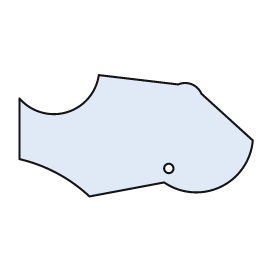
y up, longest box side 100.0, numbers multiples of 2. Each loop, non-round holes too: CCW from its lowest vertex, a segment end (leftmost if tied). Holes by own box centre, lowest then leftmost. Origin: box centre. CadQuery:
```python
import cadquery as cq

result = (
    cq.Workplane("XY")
    .moveTo(-20.0, -26.0)
    .lineTo(12.0, -20.0)
    .threePointArc((36.0, -22.0), (50.0, -2.0))
    .lineTo(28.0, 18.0)
    .threePointArc((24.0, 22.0), (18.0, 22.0))
    .lineTo(-16.0, 26.0)
    .threePointArc((-30.0, 10.0), (-50.0, 16.0))
    .lineTo(-50.0, -10.0)
    .threePointArc((-34.0, -16.0), (-20.0, -26.0))
    .close()
    .moveTo(14.0, -14.0)
    .circle(2.0)
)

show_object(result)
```